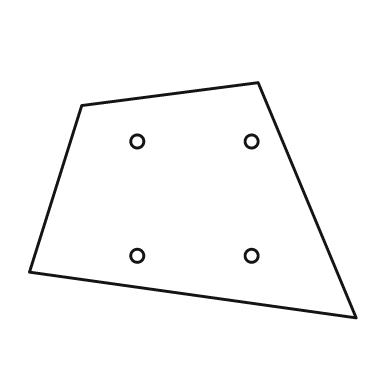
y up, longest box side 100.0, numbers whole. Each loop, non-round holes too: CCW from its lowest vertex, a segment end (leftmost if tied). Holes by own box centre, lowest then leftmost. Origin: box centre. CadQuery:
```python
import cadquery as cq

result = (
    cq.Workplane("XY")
    .moveTo(50.0, -36.0)
    .lineTo(20.0, 36.0)
    .lineTo(-34.0, 29.0)
    .lineTo(-50.0, -22.0)
    .close()
    .moveTo(-17.0, -17.0)
    .circle(2.0)
    .moveTo(18.0, -17.0)
    .circle(2.0)
    .moveTo(-17.0, 18.0)
    .circle(2.0)
    .moveTo(18.0, 18.0)
    .circle(2.0)
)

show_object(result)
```